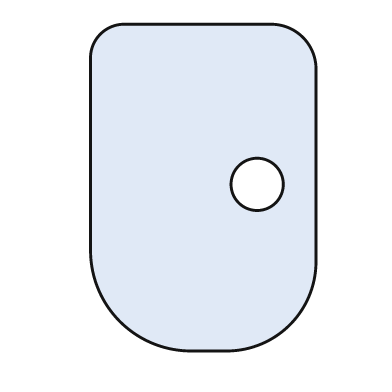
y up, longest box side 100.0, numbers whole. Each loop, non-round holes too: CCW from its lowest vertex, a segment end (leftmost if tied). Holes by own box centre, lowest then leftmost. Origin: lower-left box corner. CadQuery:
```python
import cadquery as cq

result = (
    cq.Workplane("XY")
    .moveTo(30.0, 0.0)
    .lineTo(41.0, 0.0)
    .threePointArc((61.0, 8.0), (69.0, 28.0))
    .lineTo(69.0, 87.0)
    .threePointArc((65.0, 96.0), (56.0, 100.0))
    .lineTo(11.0, 100.0)
    .threePointArc((3.0, 97.0), (0.0, 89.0))
    .lineTo(0.0, 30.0)
    .threePointArc((9.0, 9.0), (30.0, 0.0))
    .close()
    .moveTo(51.0, 51.0)
    .circle(8.0)
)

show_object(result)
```